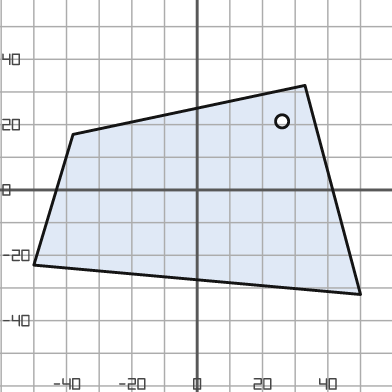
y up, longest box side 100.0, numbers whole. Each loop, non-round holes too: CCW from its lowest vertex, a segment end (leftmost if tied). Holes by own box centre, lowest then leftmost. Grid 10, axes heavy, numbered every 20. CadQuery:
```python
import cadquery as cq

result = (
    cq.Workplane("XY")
    .moveTo(50.0, -32.0)
    .lineTo(33.0, 32.0)
    .lineTo(-38.0, 17.0)
    .lineTo(-50.0, -23.0)
    .close()
    .moveTo(26.0, 21.0)
    .circle(2.0)
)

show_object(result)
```